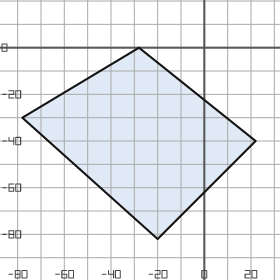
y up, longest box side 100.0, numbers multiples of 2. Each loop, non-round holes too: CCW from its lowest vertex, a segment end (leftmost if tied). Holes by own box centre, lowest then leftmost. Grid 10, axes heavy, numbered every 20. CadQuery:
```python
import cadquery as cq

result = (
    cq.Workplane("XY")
    .moveTo(-20.0, -82.0)
    .lineTo(22.0, -40.0)
    .lineTo(-28.0, 0.0)
    .lineTo(-78.0, -30.0)
    .close()
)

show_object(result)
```